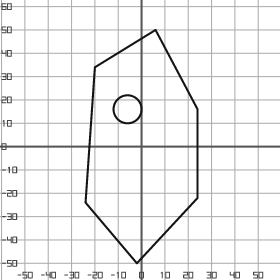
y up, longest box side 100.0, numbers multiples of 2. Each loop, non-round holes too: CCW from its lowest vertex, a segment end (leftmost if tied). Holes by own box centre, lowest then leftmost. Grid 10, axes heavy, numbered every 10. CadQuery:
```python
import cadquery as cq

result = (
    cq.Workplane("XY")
    .moveTo(-2.0, -50.0)
    .lineTo(24.0, -22.0)
    .lineTo(24.0, 16.0)
    .lineTo(6.0, 50.0)
    .lineTo(-20.0, 34.0)
    .lineTo(-24.0, -24.0)
    .close()
    .moveTo(-6.0, 16.0)
    .circle(6.0)
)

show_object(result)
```